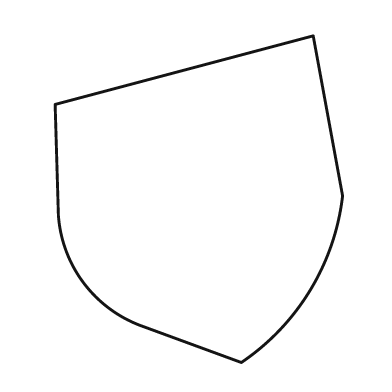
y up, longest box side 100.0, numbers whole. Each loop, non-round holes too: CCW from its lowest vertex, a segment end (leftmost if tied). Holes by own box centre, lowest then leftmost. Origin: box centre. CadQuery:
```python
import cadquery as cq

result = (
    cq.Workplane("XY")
    .moveTo(13.0, -50.0)
    .threePointArc((34.0, -28.0), (44.0, 1.0))
    .lineTo(35.0, 50.0)
    .lineTo(-44.0, 29.0)
    .lineTo(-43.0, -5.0)
    .threePointArc((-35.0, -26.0), (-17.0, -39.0))
    .close()
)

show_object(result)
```